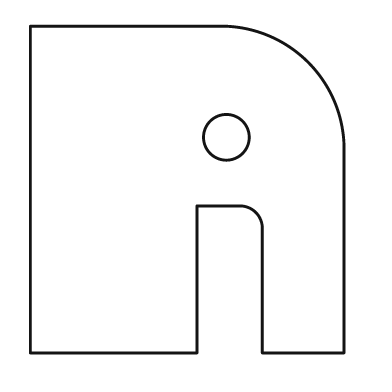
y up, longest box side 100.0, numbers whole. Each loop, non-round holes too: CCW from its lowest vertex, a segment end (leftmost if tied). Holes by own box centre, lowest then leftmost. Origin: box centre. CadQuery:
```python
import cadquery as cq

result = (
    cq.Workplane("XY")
    .moveTo(-48.0, -50.0)
    .lineTo(3.0, -50.0)
    .lineTo(3.0, -5.0)
    .lineTo(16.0, -5.0)
    .threePointArc((21.0, -7.0), (23.0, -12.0))
    .lineTo(23.0, -50.0)
    .lineTo(48.0, -50.0)
    .lineTo(48.0, 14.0)
    .threePointArc((37.0, 39.0), (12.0, 50.0))
    .lineTo(-48.0, 50.0)
    .close()
    .moveTo(12.0, 16.0)
    .circle(7.0)
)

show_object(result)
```